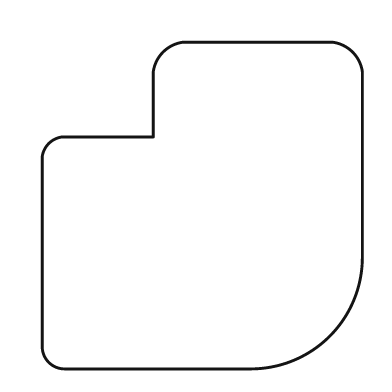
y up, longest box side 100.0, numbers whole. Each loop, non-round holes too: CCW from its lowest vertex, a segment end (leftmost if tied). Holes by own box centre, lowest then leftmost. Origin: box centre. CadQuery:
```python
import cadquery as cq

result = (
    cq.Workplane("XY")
    .moveTo(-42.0, -50.0)
    .lineTo(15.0, -50.0)
    .threePointArc((39.0, -40.0), (49.0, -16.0))
    .lineTo(49.0, 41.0)
    .threePointArc((46.0, 47.0), (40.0, 50.0))
    .lineTo(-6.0, 50.0)
    .threePointArc((-12.0, 47.0), (-15.0, 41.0))
    .lineTo(-15.0, 21.0)
    .lineTo(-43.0, 21.0)
    .threePointArc((-47.0, 19.0), (-49.0, 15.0))
    .lineTo(-49.0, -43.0)
    .threePointArc((-47.0, -48.0), (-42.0, -50.0))
    .close()
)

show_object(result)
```